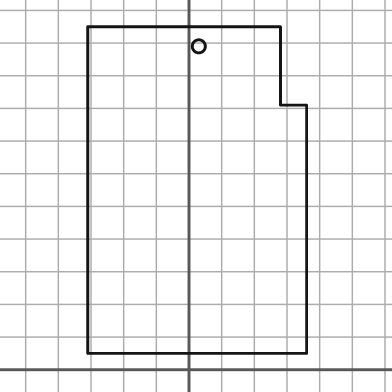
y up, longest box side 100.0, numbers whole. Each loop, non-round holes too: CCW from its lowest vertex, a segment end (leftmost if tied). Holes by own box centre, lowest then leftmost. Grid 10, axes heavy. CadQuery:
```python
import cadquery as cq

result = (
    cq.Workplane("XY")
    .moveTo(-31.0, 5.0)
    .lineTo(36.0, 5.0)
    .lineTo(36.0, 81.0)
    .lineTo(28.0, 81.0)
    .lineTo(28.0, 105.0)
    .lineTo(-31.0, 105.0)
    .close()
    .moveTo(3.0, 99.0)
    .circle(2.0)
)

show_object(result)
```